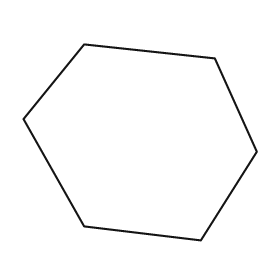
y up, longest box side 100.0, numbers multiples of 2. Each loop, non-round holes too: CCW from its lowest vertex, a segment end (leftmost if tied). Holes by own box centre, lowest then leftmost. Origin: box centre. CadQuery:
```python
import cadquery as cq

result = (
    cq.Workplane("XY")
    .moveTo(26.0, -42.0)
    .lineTo(50.0, -4.0)
    .lineTo(32.0, 36.0)
    .lineTo(-24.0, 42.0)
    .lineTo(-50.0, 10.0)
    .lineTo(-24.0, -36.0)
    .close()
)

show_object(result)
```